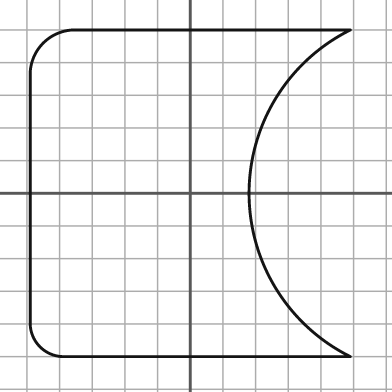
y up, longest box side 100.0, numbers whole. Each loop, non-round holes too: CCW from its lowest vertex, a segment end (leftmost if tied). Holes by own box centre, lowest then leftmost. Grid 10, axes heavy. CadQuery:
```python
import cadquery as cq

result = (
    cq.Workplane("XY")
    .moveTo(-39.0, -50.0)
    .lineTo(49.0, -50.0)
    .threePointArc((18.0, 0.0), (49.0, 50.0))
    .lineTo(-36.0, 50.0)
    .threePointArc((-45.0, 46.0), (-49.0, 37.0))
    .lineTo(-49.0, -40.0)
    .threePointArc((-46.0, -47.0), (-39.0, -50.0))
    .close()
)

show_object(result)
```